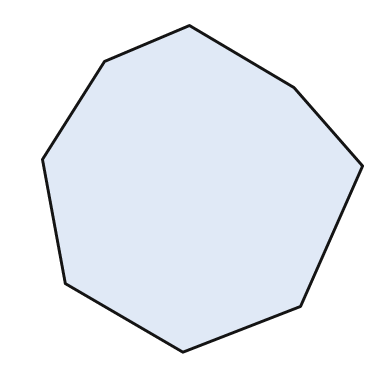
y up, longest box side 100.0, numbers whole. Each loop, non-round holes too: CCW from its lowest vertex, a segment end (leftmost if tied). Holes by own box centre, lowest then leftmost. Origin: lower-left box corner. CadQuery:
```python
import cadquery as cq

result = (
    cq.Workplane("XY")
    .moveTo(43.0, 0.0)
    .lineTo(79.0, 14.0)
    .lineTo(98.0, 57.0)
    .lineTo(77.0, 81.0)
    .lineTo(45.0, 100.0)
    .lineTo(19.0, 89.0)
    .lineTo(0.0, 59.0)
    .lineTo(7.0, 21.0)
    .close()
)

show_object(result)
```